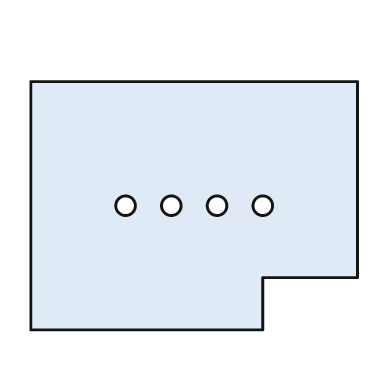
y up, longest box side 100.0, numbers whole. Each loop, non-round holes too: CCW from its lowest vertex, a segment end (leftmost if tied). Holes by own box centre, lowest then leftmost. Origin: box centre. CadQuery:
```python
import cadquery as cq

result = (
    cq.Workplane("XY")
    .moveTo(-50.0, -38.0)
    .lineTo(21.0, -38.0)
    .lineTo(21.0, -22.0)
    .lineTo(50.0, -22.0)
    .lineTo(50.0, 38.0)
    .lineTo(-50.0, 38.0)
    .close()
    .moveTo(-21.0, 0.0)
    .circle(3.0)
    .moveTo(-7.0, 0.0)
    .circle(3.0)
    .moveTo(7.0, 0.0)
    .circle(3.0)
    .moveTo(21.0, 0.0)
    .circle(3.0)
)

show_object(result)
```